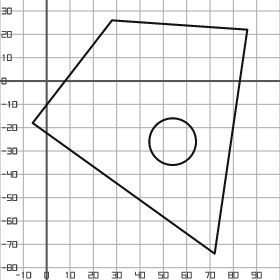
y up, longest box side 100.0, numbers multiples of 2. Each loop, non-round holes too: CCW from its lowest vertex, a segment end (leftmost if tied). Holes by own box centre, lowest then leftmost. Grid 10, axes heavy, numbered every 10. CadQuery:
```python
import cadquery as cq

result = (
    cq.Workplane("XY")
    .moveTo(72.0, -74.0)
    .lineTo(86.0, 22.0)
    .lineTo(28.0, 26.0)
    .lineTo(-6.0, -18.0)
    .close()
    .moveTo(54.0, -26.0)
    .circle(10.0)
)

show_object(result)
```